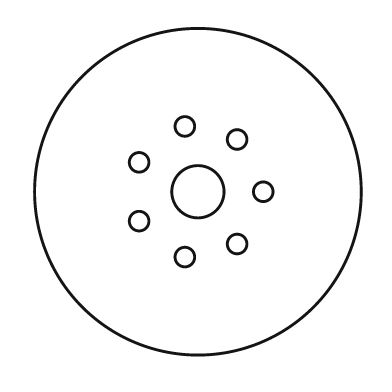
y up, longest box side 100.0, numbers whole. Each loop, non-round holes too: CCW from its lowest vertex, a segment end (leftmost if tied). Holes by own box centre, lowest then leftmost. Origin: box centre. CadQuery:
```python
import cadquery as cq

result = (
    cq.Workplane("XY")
    .moveTo(0.0, 0.0)
    .circle(50.0)
    .moveTo(-4.0, -20.0)
    .circle(3.0)
    .moveTo(12.0, -16.0)
    .circle(3.0)
    .moveTo(-18.0, -9.0)
    .circle(3.0)
    .moveTo(0.0, 0.0)
    .circle(8.0)
    .moveTo(20.0, 0.0)
    .circle(3.0)
    .moveTo(-18.0, 9.0)
    .circle(3.0)
    .moveTo(12.0, 16.0)
    .circle(3.0)
    .moveTo(-4.0, 20.0)
    .circle(3.0)
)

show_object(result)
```